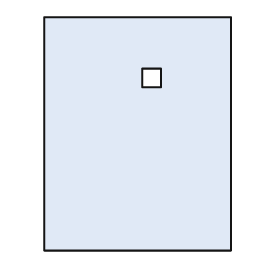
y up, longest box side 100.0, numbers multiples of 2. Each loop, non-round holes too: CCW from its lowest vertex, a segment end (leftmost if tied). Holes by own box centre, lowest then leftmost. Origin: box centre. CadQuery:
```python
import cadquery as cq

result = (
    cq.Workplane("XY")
    .moveTo(-40.0, -50.0)
    .lineTo(40.0, -50.0)
    .lineTo(40.0, 50.0)
    .lineTo(-40.0, 50.0)
    .close()
    .moveTo(2.0, 20.0)
    .lineTo(10.0, 20.0)
    .lineTo(10.0, 28.0)
    .lineTo(2.0, 28.0)
    .close()
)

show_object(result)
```